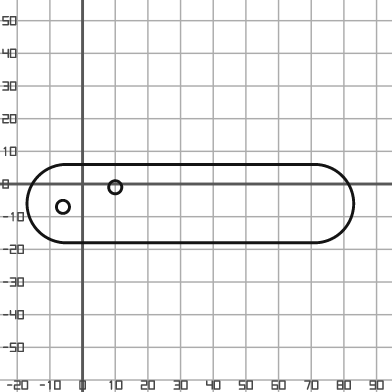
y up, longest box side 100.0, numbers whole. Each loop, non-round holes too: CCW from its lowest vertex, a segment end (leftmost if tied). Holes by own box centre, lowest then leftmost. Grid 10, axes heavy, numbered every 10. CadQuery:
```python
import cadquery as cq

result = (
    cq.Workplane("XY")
    .moveTo(-5.0, -18.0)
    .lineTo(71.0, -18.0)
    .threePointArc((83.0, -6.0), (71.0, 6.0))
    .lineTo(-5.0, 6.0)
    .threePointArc((-17.0, -6.0), (-5.0, -18.0))
    .close()
    .moveTo(-6.0, -7.0)
    .circle(2.0)
    .moveTo(10.0, -1.0)
    .circle(2.0)
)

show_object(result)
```